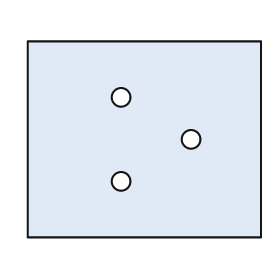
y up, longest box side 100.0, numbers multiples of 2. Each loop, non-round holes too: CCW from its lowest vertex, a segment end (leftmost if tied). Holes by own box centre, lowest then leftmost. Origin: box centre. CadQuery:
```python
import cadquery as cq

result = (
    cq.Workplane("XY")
    .moveTo(-50.0, -42.0)
    .lineTo(50.0, -42.0)
    .lineTo(50.0, 42.0)
    .lineTo(-50.0, 42.0)
    .close()
    .moveTo(-10.0, -18.0)
    .circle(4.0)
    .moveTo(20.0, 0.0)
    .circle(4.0)
    .moveTo(-10.0, 18.0)
    .circle(4.0)
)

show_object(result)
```